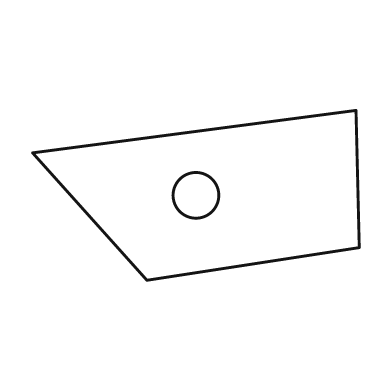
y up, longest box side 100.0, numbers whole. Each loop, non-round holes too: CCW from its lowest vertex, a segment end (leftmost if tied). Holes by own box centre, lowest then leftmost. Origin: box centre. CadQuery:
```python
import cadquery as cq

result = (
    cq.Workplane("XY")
    .moveTo(-15.0, -26.0)
    .lineTo(50.0, -16.0)
    .lineTo(49.0, 26.0)
    .lineTo(-50.0, 13.0)
    .close()
    .moveTo(0.0, 0.0)
    .circle(7.0)
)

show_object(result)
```